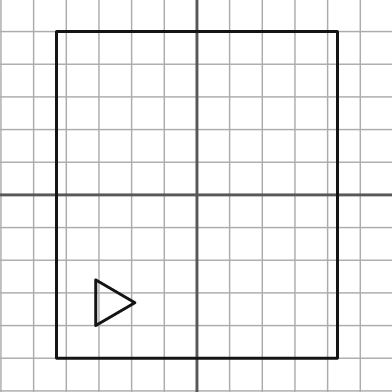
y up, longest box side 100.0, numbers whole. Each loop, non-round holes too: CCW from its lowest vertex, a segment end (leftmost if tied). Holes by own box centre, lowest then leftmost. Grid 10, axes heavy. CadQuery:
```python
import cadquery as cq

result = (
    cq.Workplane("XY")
    .moveTo(-43.0, -50.0)
    .lineTo(43.0, -50.0)
    .lineTo(43.0, 50.0)
    .lineTo(-43.0, 50.0)
    .close()
    .moveTo(-31.0, -40.0)
    .lineTo(-19.0, -33.0)
    .lineTo(-31.0, -26.0)
    .close()
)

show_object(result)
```